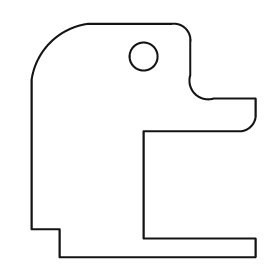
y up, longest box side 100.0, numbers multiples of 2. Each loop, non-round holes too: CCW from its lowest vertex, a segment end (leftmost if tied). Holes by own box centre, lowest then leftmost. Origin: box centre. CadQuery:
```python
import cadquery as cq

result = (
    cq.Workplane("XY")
    .moveTo(-36.0, -50.0)
    .lineTo(48.0, -50.0)
    .lineTo(48.0, -42.0)
    .lineTo(0.0, -42.0)
    .lineTo(0.0, 4.0)
    .lineTo(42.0, 4.0)
    .threePointArc((46.0, 6.0), (48.0, 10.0))
    .lineTo(48.0, 18.0)
    .lineTo(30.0, 18.0)
    .threePointArc((22.0, 20.0), (20.0, 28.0))
    .lineTo(20.0, 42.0)
    .threePointArc((18.0, 48.0), (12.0, 50.0))
    .lineTo(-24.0, 50.0)
    .threePointArc((-40.0, 42.0), (-48.0, 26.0))
    .lineTo(-48.0, -38.0)
    .lineTo(-36.0, -38.0)
    .close()
    .moveTo(0.0, 36.0)
    .circle(6.0)
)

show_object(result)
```